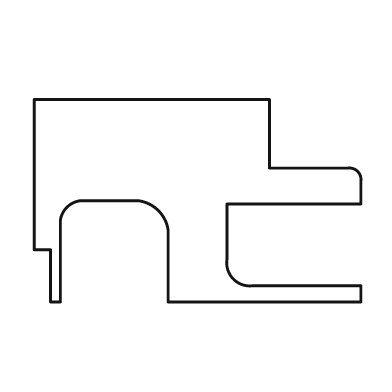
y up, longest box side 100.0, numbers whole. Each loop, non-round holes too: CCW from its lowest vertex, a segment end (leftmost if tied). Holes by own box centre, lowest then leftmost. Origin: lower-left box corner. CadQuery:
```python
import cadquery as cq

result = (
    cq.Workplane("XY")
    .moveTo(5.0, 0.0)
    .lineTo(8.0, 0.0)
    .lineTo(8.0, 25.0)
    .threePointArc((10.0, 29.0), (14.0, 31.0))
    .lineTo(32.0, 31.0)
    .threePointArc((38.0, 28.0), (41.0, 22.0))
    .lineTo(41.0, 0.0)
    .lineTo(100.0, 0.0)
    .lineTo(100.0, 5.0)
    .lineTo(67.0, 5.0)
    .threePointArc((61.0, 7.0), (59.0, 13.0))
    .lineTo(59.0, 30.0)
    .lineTo(100.0, 30.0)
    .lineTo(100.0, 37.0)
    .threePointArc((99.0, 40.0), (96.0, 41.0))
    .lineTo(72.0, 41.0)
    .lineTo(72.0, 62.0)
    .lineTo(0.0, 62.0)
    .lineTo(0.0, 16.0)
    .lineTo(5.0, 16.0)
    .close()
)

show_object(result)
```